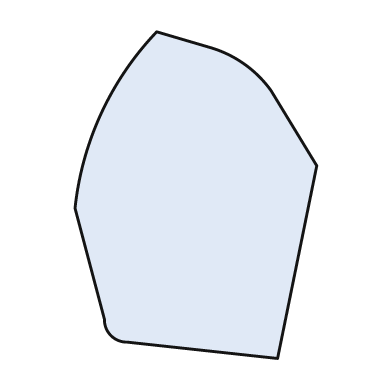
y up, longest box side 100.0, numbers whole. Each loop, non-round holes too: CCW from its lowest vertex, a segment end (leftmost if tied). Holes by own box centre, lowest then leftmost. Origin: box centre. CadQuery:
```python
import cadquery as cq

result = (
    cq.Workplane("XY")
    .moveTo(25.0, -50.0)
    .lineTo(37.0, 9.0)
    .lineTo(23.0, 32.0)
    .threePointArc((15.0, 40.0), (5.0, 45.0))
    .lineTo(-12.0, 50.0)
    .threePointArc((-29.0, 25.0), (-37.0, -4.0))
    .lineTo(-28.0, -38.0)
    .threePointArc((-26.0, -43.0), (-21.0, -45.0))
    .close()
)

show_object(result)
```